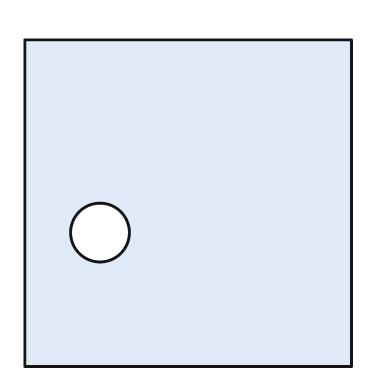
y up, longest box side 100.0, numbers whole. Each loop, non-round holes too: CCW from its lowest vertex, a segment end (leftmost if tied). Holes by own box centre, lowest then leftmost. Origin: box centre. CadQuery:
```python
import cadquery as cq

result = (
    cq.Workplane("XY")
    .moveTo(-50.0, -50.0)
    .lineTo(50.0, -50.0)
    .lineTo(50.0, 50.0)
    .lineTo(-50.0, 50.0)
    .close()
    .moveTo(-27.0, -9.0)
    .circle(9.0)
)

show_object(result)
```